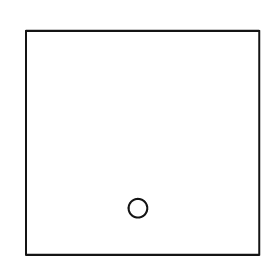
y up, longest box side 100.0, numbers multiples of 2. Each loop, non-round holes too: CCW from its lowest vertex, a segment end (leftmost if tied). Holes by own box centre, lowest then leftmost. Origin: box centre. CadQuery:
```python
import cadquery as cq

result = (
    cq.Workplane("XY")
    .moveTo(-50.0, -48.0)
    .lineTo(50.0, -48.0)
    .lineTo(50.0, 48.0)
    .lineTo(-50.0, 48.0)
    .close()
    .moveTo(-2.0, -28.0)
    .circle(4.0)
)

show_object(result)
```